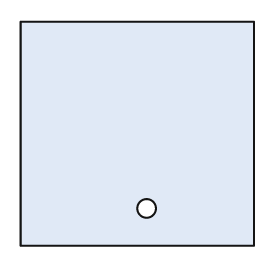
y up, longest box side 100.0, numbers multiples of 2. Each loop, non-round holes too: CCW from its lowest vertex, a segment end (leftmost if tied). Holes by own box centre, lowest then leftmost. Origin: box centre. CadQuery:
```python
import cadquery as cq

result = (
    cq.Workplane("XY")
    .moveTo(-50.0, -48.0)
    .lineTo(50.0, -48.0)
    .lineTo(50.0, 48.0)
    .lineTo(-50.0, 48.0)
    .close()
    .moveTo(4.0, -32.0)
    .circle(4.0)
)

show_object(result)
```